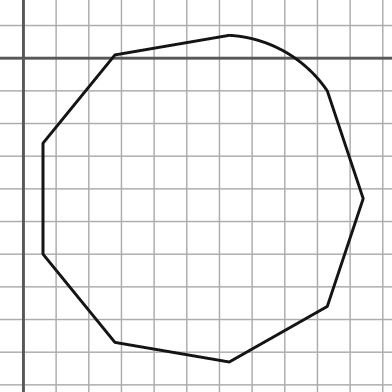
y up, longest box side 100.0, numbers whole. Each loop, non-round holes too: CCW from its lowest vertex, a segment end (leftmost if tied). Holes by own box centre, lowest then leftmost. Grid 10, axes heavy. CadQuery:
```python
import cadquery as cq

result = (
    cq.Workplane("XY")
    .moveTo(63.0, -93.0)
    .lineTo(93.0, -76.0)
    .lineTo(104.0, -43.0)
    .lineTo(93.0, -10.0)
    .threePointArc((80.0, 2.0), (63.0, 7.0))
    .lineTo(28.0, 1.0)
    .lineTo(6.0, -26.0)
    .lineTo(6.0, -60.0)
    .lineTo(28.0, -87.0)
    .close()
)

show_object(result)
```